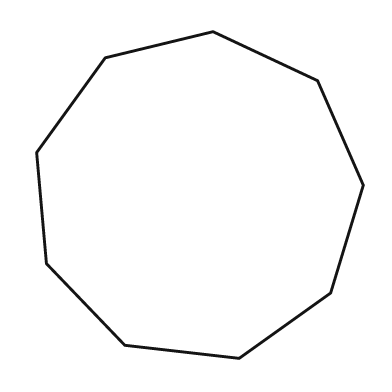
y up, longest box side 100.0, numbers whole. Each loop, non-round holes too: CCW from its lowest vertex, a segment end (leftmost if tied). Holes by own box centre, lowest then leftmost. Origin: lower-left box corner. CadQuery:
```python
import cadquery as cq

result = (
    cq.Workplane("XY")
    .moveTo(62.0, 0.0)
    .lineTo(90.0, 20.0)
    .lineTo(100.0, 53.0)
    .lineTo(86.0, 85.0)
    .lineTo(54.0, 100.0)
    .lineTo(21.0, 92.0)
    .lineTo(0.0, 63.0)
    .lineTo(3.0, 29.0)
    .lineTo(27.0, 4.0)
    .close()
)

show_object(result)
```